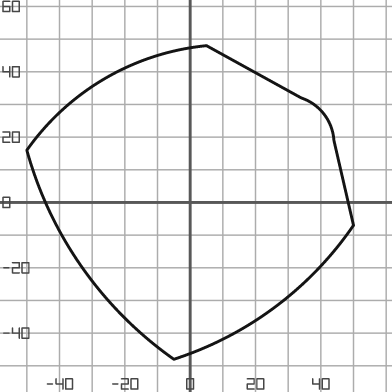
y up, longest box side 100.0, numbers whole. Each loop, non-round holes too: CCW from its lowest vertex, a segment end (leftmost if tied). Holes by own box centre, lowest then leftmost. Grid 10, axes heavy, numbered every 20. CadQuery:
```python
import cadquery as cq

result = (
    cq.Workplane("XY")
    .moveTo(-5.0, -48.0)
    .threePointArc((26.0, -32.0), (50.0, -7.0))
    .lineTo(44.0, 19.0)
    .threePointArc((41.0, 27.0), (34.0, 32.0))
    .lineTo(5.0, 48.0)
    .threePointArc((-26.0, 38.0), (-50.0, 16.0))
    .threePointArc((-33.0, -20.0), (-5.0, -48.0))
    .close()
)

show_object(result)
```